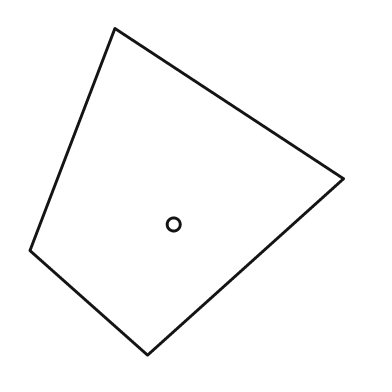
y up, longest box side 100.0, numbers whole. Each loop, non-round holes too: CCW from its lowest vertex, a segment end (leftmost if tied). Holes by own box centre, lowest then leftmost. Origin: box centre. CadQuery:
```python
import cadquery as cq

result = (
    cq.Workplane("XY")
    .moveTo(-12.0, -50.0)
    .lineTo(48.0, 4.0)
    .lineTo(-22.0, 50.0)
    .lineTo(-48.0, -18.0)
    .close()
    .moveTo(-4.0, -10.0)
    .circle(2.0)
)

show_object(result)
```